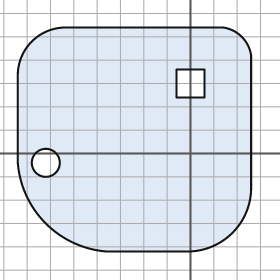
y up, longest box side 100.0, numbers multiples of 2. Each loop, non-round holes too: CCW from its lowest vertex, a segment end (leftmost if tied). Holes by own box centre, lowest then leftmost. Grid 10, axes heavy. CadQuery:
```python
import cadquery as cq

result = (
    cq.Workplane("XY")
    .moveTo(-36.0, -42.0)
    .lineTo(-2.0, -42.0)
    .threePointArc((18.0, -34.0), (26.0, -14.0))
    .lineTo(26.0, 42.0)
    .threePointArc((22.0, 50.0), (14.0, 54.0))
    .lineTo(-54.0, 54.0)
    .threePointArc((-68.0, 48.0), (-74.0, 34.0))
    .lineTo(-74.0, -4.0)
    .threePointArc((-62.0, -30.0), (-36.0, -42.0))
    .close()
    .moveTo(-62.0, -4.0)
    .circle(6.0)
    .moveTo(-6.0, 24.0)
    .lineTo(6.0, 24.0)
    .lineTo(6.0, 36.0)
    .lineTo(-6.0, 36.0)
    .close()
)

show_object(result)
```